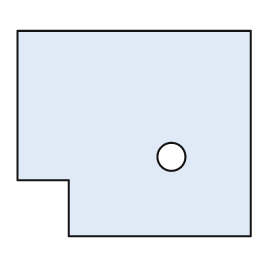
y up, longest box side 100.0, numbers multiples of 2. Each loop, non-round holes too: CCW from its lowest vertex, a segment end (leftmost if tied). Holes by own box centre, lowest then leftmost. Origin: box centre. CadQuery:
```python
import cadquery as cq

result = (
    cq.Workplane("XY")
    .moveTo(-28.0, -44.0)
    .lineTo(50.0, -44.0)
    .lineTo(50.0, 44.0)
    .lineTo(-50.0, 44.0)
    .lineTo(-50.0, -20.0)
    .lineTo(-28.0, -20.0)
    .close()
    .moveTo(16.0, -10.0)
    .circle(6.0)
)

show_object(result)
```